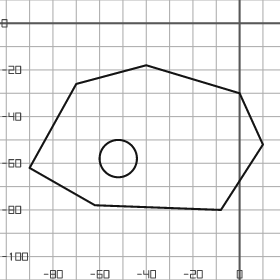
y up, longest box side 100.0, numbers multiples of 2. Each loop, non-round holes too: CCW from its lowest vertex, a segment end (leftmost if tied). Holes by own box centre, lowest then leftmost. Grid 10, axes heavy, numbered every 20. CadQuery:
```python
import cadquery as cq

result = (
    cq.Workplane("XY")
    .moveTo(-8.0, -80.0)
    .lineTo(10.0, -52.0)
    .lineTo(0.0, -30.0)
    .lineTo(-40.0, -18.0)
    .lineTo(-70.0, -26.0)
    .lineTo(-90.0, -62.0)
    .lineTo(-62.0, -78.0)
    .close()
    .moveTo(-52.0, -58.0)
    .circle(8.0)
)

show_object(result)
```